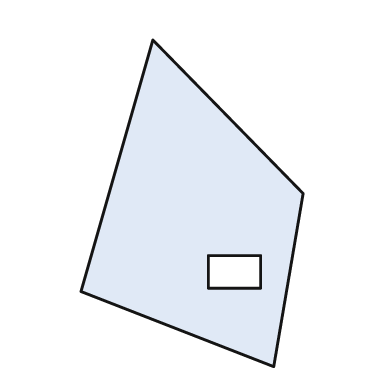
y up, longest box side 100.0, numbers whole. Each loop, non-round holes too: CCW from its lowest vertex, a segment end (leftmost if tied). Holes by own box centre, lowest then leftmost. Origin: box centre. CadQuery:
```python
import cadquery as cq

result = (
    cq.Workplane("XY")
    .moveTo(25.0, -50.0)
    .lineTo(34.0, 3.0)
    .lineTo(-12.0, 50.0)
    .lineTo(-34.0, -27.0)
    .close()
    .moveTo(5.0, -26.0)
    .lineTo(21.0, -26.0)
    .lineTo(21.0, -16.0)
    .lineTo(5.0, -16.0)
    .close()
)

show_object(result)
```